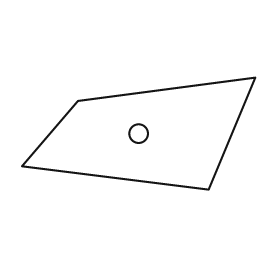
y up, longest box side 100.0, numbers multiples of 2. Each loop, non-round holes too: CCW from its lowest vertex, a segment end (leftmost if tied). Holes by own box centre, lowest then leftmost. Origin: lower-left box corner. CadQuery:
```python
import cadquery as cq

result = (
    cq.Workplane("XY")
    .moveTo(80.0, 0.0)
    .lineTo(100.0, 48.0)
    .lineTo(24.0, 38.0)
    .lineTo(0.0, 10.0)
    .close()
    .moveTo(50.0, 24.0)
    .circle(4.0)
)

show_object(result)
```